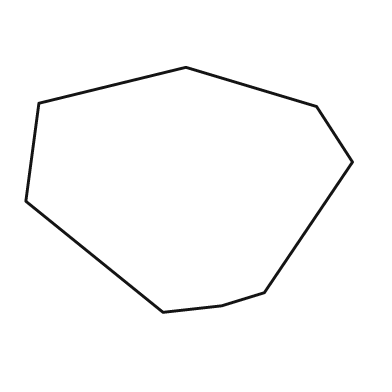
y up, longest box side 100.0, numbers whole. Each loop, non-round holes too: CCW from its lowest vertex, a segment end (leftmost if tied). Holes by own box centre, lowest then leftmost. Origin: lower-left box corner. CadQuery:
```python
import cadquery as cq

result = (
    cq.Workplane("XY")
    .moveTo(42.0, 0.0)
    .lineTo(60.0, 2.0)
    .lineTo(73.0, 6.0)
    .lineTo(100.0, 46.0)
    .lineTo(89.0, 63.0)
    .lineTo(49.0, 75.0)
    .lineTo(4.0, 64.0)
    .lineTo(0.0, 34.0)
    .close()
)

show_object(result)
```